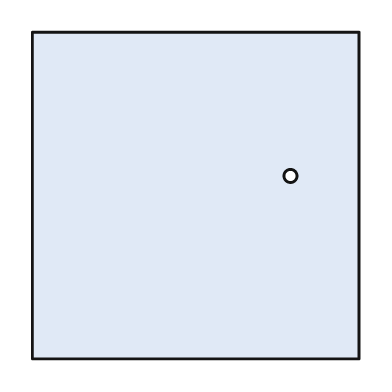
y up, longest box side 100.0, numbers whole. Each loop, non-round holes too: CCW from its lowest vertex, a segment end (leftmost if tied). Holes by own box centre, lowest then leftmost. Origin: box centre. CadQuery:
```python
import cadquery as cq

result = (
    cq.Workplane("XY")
    .moveTo(-50.0, -50.0)
    .lineTo(50.0, -50.0)
    .lineTo(50.0, 50.0)
    .lineTo(-50.0, 50.0)
    .close()
    .moveTo(29.0, 6.0)
    .circle(2.0)
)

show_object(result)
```